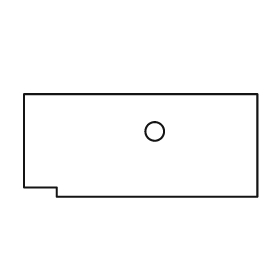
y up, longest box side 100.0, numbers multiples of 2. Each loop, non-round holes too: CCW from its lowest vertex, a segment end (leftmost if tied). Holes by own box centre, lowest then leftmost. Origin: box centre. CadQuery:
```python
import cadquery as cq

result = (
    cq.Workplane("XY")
    .moveTo(-36.0, -22.0)
    .lineTo(50.0, -22.0)
    .lineTo(50.0, 22.0)
    .lineTo(-50.0, 22.0)
    .lineTo(-50.0, -18.0)
    .lineTo(-36.0, -18.0)
    .close()
    .moveTo(6.0, 6.0)
    .circle(4.0)
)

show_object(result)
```